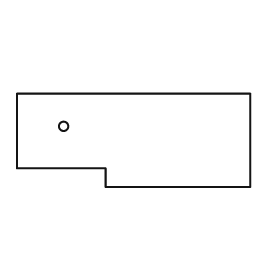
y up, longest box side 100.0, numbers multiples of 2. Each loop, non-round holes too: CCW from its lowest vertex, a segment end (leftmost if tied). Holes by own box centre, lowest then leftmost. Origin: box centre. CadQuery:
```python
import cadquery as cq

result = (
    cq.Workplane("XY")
    .moveTo(-12.0, -20.0)
    .lineTo(50.0, -20.0)
    .lineTo(50.0, 20.0)
    .lineTo(-50.0, 20.0)
    .lineTo(-50.0, -12.0)
    .lineTo(-12.0, -12.0)
    .close()
    .moveTo(-30.0, 6.0)
    .circle(2.0)
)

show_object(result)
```